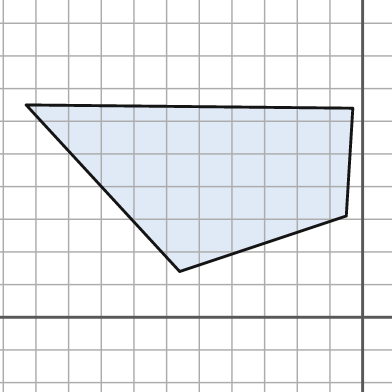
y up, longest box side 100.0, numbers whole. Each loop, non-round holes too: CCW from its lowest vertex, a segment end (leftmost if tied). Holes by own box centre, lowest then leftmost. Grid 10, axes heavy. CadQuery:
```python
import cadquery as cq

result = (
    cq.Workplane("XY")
    .moveTo(-56.0, 14.0)
    .lineTo(-5.0, 31.0)
    .lineTo(-3.0, 64.0)
    .lineTo(-103.0, 65.0)
    .close()
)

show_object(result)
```